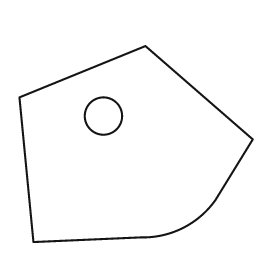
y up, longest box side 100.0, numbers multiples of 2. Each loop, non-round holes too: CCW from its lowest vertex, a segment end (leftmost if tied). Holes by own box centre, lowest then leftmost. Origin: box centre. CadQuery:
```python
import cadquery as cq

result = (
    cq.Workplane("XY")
    .moveTo(-44.0, -42.0)
    .lineTo(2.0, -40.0)
    .threePointArc((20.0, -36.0), (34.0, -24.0))
    .lineTo(50.0, 2.0)
    .lineTo(4.0, 42.0)
    .lineTo(-50.0, 20.0)
    .close()
    .moveTo(-14.0, 12.0)
    .circle(8.0)
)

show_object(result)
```